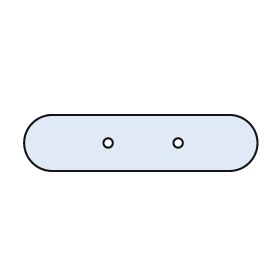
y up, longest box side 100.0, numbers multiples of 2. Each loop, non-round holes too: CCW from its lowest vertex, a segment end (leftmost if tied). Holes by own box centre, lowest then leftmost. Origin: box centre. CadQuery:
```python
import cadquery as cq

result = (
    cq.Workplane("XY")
    .moveTo(-38.0, -12.0)
    .lineTo(38.0, -12.0)
    .threePointArc((50.0, 0.0), (38.0, 12.0))
    .lineTo(-38.0, 12.0)
    .threePointArc((-50.0, 0.0), (-38.0, -12.0))
    .close()
    .moveTo(-14.0, 0.0)
    .circle(2.0)
    .moveTo(16.0, 0.0)
    .circle(2.0)
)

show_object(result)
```